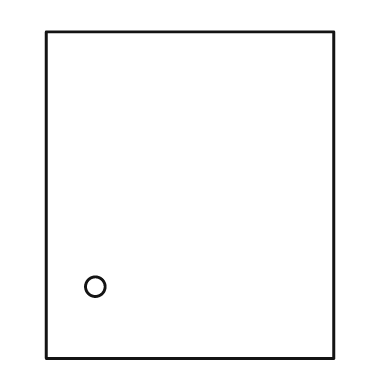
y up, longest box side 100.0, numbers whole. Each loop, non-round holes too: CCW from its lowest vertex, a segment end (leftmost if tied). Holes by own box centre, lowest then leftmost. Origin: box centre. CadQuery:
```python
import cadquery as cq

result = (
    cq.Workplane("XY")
    .moveTo(-44.0, -50.0)
    .lineTo(44.0, -50.0)
    .lineTo(44.0, 50.0)
    .lineTo(-44.0, 50.0)
    .close()
    .moveTo(-29.0, -28.0)
    .circle(3.0)
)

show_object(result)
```